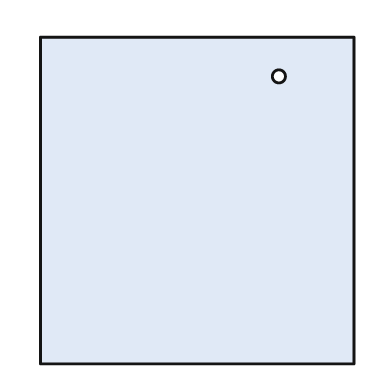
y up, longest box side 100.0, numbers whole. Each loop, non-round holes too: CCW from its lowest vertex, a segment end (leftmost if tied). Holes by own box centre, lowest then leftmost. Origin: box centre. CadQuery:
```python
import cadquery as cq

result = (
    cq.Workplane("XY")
    .moveTo(-48.0, -50.0)
    .lineTo(48.0, -50.0)
    .lineTo(48.0, 50.0)
    .lineTo(-48.0, 50.0)
    .close()
    .moveTo(25.0, 38.0)
    .circle(2.0)
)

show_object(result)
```